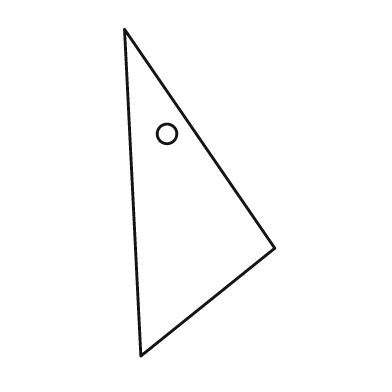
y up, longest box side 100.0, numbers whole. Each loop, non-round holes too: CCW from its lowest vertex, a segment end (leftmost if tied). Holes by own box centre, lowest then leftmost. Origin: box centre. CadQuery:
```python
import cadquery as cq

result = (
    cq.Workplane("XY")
    .moveTo(-18.0, -50.0)
    .lineTo(23.0, -17.0)
    .lineTo(-23.0, 50.0)
    .close()
    .moveTo(-10.0, 18.0)
    .circle(3.0)
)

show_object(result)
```